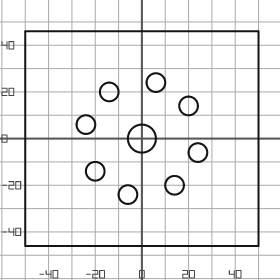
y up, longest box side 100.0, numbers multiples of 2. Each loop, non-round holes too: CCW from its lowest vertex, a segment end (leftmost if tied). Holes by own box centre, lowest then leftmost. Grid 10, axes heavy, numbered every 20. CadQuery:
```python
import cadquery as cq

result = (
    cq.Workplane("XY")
    .moveTo(-50.0, -46.0)
    .lineTo(50.0, -46.0)
    .lineTo(50.0, 46.0)
    .lineTo(-50.0, 46.0)
    .close()
    .moveTo(-6.0, -24.0)
    .circle(4.0)
    .moveTo(14.0, -20.0)
    .circle(4.0)
    .moveTo(-20.0, -14.0)
    .circle(4.0)
    .moveTo(24.0, -6.0)
    .circle(4.0)
    .moveTo(0.0, 0.0)
    .circle(6.0)
    .moveTo(-24.0, 6.0)
    .circle(4.0)
    .moveTo(20.0, 14.0)
    .circle(4.0)
    .moveTo(-14.0, 20.0)
    .circle(4.0)
    .moveTo(6.0, 24.0)
    .circle(4.0)
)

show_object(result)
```